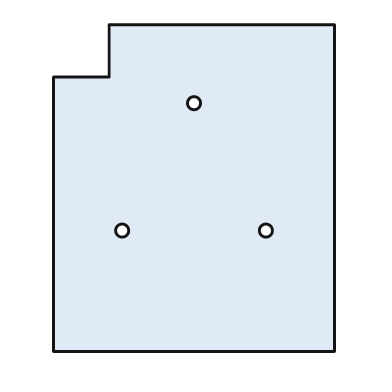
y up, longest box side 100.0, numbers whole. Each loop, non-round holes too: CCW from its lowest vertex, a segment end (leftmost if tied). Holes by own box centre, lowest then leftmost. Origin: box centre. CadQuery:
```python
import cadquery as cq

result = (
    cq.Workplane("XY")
    .moveTo(-43.0, -50.0)
    .lineTo(43.0, -50.0)
    .lineTo(43.0, 50.0)
    .lineTo(-26.0, 50.0)
    .lineTo(-26.0, 34.0)
    .lineTo(-43.0, 34.0)
    .close()
    .moveTo(-22.0, -13.0)
    .circle(2.0)
    .moveTo(22.0, -13.0)
    .circle(2.0)
    .moveTo(0.0, 26.0)
    .circle(2.0)
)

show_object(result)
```